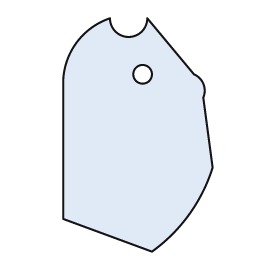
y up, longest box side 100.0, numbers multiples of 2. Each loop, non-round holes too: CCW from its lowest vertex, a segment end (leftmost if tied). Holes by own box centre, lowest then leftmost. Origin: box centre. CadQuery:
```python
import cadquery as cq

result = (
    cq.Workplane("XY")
    .moveTo(6.0, -50.0)
    .threePointArc((22.0, -34.0), (32.0, -14.0))
    .lineTo(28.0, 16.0)
    .threePointArc((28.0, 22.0), (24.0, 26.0))
    .lineTo(4.0, 50.0)
    .threePointArc((-4.0, 42.0), (-12.0, 50.0))
    .threePointArc((-26.0, 40.0), (-32.0, 24.0))
    .lineTo(-32.0, -36.0)
    .close()
    .moveTo(2.0, 26.0)
    .circle(4.0)
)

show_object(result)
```